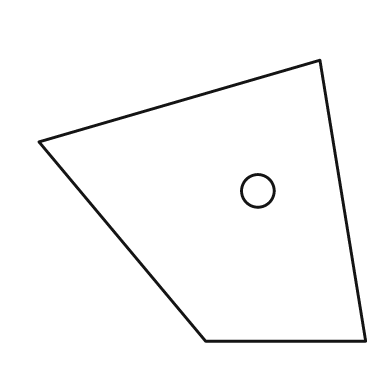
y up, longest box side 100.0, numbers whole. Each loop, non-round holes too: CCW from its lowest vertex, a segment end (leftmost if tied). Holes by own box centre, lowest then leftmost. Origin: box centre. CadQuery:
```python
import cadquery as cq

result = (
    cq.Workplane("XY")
    .moveTo(1.0, -43.0)
    .lineTo(50.0, -43.0)
    .lineTo(36.0, 43.0)
    .lineTo(-50.0, 18.0)
    .close()
    .moveTo(17.0, 3.0)
    .circle(5.0)
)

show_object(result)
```